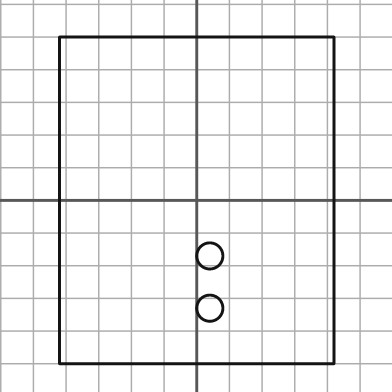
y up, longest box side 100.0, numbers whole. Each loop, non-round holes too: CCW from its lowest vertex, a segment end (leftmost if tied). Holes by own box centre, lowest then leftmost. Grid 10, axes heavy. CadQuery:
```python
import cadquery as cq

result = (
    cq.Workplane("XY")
    .moveTo(-42.0, -50.0)
    .lineTo(42.0, -50.0)
    .lineTo(42.0, 50.0)
    .lineTo(-42.0, 50.0)
    .close()
    .moveTo(4.0, -33.0)
    .circle(4.0)
    .moveTo(4.0, -17.0)
    .circle(4.0)
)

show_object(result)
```